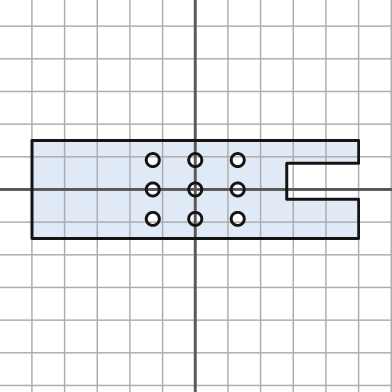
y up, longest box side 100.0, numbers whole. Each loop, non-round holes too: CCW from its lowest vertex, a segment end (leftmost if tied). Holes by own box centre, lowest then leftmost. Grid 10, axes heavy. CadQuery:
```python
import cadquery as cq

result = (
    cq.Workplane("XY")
    .moveTo(-50.0, -15.0)
    .lineTo(50.0, -15.0)
    .lineTo(50.0, -3.0)
    .lineTo(28.0, -3.0)
    .lineTo(28.0, 8.0)
    .lineTo(50.0, 8.0)
    .lineTo(50.0, 15.0)
    .lineTo(-50.0, 15.0)
    .close()
    .moveTo(-13.0, -9.0)
    .circle(2.0)
    .moveTo(0.0, -9.0)
    .circle(2.0)
    .moveTo(13.0, -9.0)
    .circle(2.0)
    .moveTo(-13.0, 0.0)
    .circle(2.0)
    .moveTo(0.0, 0.0)
    .circle(2.0)
    .moveTo(13.0, 0.0)
    .circle(2.0)
    .moveTo(-13.0, 9.0)
    .circle(2.0)
    .moveTo(0.0, 9.0)
    .circle(2.0)
    .moveTo(13.0, 9.0)
    .circle(2.0)
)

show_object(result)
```